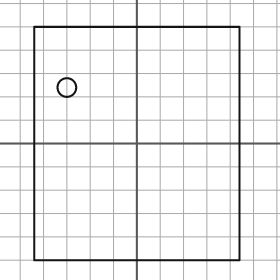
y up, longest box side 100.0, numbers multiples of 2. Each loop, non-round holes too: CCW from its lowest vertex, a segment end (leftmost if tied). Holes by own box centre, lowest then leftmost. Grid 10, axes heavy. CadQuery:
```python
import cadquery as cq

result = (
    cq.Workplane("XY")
    .moveTo(-44.0, -50.0)
    .lineTo(44.0, -50.0)
    .lineTo(44.0, 50.0)
    .lineTo(-44.0, 50.0)
    .close()
    .moveTo(-30.0, 24.0)
    .circle(4.0)
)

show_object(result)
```